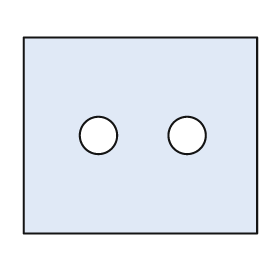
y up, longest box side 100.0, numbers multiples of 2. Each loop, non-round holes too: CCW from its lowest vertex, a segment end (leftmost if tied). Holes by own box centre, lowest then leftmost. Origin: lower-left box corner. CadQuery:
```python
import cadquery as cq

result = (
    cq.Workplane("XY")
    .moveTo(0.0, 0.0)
    .lineTo(100.0, 0.0)
    .lineTo(100.0, 84.0)
    .lineTo(0.0, 84.0)
    .close()
    .moveTo(32.0, 42.0)
    .circle(8.0)
    .moveTo(70.0, 42.0)
    .circle(8.0)
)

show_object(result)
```